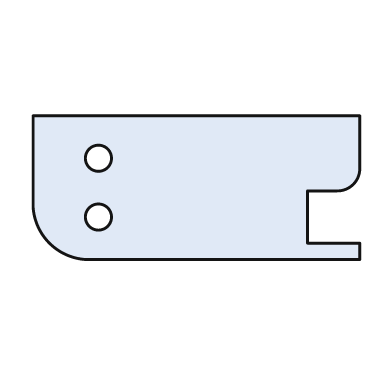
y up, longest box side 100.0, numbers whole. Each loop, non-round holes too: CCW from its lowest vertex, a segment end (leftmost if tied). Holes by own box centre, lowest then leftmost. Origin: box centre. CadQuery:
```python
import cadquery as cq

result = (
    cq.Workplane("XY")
    .moveTo(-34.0, -22.0)
    .lineTo(50.0, -22.0)
    .lineTo(50.0, -17.0)
    .lineTo(34.0, -17.0)
    .lineTo(34.0, -1.0)
    .lineTo(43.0, -1.0)
    .threePointArc((48.0, 1.0), (50.0, 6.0))
    .lineTo(50.0, 22.0)
    .lineTo(-50.0, 22.0)
    .lineTo(-50.0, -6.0)
    .threePointArc((-45.0, -17.0), (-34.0, -22.0))
    .close()
    .moveTo(-30.0, -9.0)
    .circle(4.0)
    .moveTo(-30.0, 9.0)
    .circle(4.0)
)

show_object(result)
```